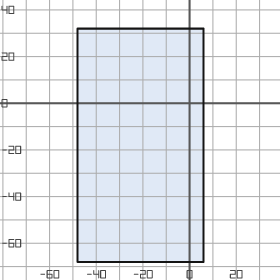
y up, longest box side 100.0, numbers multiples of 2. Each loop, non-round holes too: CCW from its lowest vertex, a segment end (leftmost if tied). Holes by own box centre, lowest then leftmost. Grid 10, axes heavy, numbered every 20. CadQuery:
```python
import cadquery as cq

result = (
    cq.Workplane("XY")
    .moveTo(-48.0, -68.0)
    .lineTo(6.0, -68.0)
    .lineTo(6.0, 32.0)
    .lineTo(-48.0, 32.0)
    .close()
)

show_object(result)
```